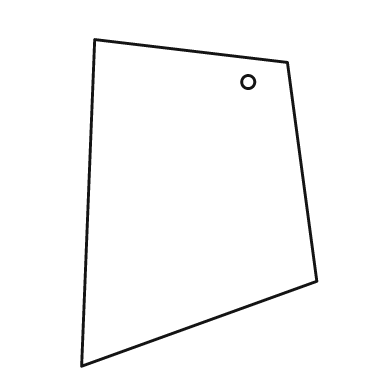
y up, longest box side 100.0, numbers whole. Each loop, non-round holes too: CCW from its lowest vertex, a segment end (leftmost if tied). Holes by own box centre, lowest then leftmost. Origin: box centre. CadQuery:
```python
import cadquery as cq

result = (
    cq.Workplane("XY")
    .moveTo(-36.0, -50.0)
    .lineTo(36.0, -24.0)
    .lineTo(27.0, 43.0)
    .lineTo(-32.0, 50.0)
    .close()
    .moveTo(15.0, 37.0)
    .circle(2.0)
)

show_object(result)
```